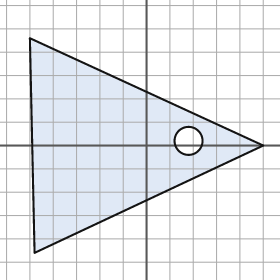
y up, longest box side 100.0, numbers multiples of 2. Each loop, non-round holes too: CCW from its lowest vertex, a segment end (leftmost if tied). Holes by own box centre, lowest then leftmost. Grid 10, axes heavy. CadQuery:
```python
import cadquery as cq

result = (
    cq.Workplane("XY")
    .moveTo(-48.0, -46.0)
    .lineTo(50.0, 0.0)
    .lineTo(-50.0, 46.0)
    .close()
    .moveTo(18.0, 2.0)
    .circle(6.0)
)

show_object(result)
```